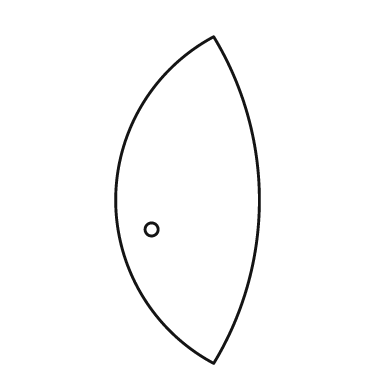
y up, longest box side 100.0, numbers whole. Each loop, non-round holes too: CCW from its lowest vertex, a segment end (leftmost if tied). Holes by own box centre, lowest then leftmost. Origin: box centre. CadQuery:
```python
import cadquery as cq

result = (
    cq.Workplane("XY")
    .moveTo(8.0, -50.0)
    .threePointArc((22.0, 0.0), (8.0, 50.0))
    .threePointArc((-22.0, 0.0), (8.0, -50.0))
    .close()
    .moveTo(-11.0, -9.0)
    .circle(2.0)
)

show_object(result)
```